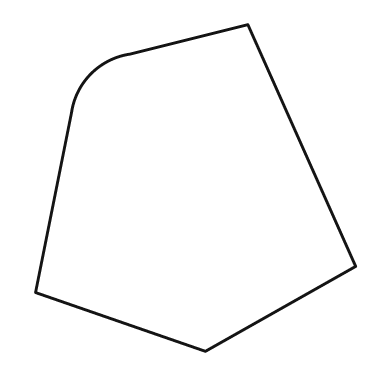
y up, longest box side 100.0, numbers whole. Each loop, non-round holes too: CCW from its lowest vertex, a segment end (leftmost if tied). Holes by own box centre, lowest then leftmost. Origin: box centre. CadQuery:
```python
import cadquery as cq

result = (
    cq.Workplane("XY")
    .moveTo(3.0, -50.0)
    .lineTo(49.0, -24.0)
    .lineTo(16.0, 50.0)
    .lineTo(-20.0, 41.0)
    .threePointArc((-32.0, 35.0), (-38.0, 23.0))
    .lineTo(-49.0, -32.0)
    .close()
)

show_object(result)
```